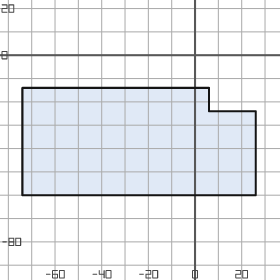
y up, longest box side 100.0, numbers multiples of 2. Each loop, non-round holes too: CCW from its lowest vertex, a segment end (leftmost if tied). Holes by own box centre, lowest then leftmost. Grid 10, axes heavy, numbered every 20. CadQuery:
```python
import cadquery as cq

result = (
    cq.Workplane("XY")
    .moveTo(-74.0, -60.0)
    .lineTo(26.0, -60.0)
    .lineTo(26.0, -24.0)
    .lineTo(6.0, -24.0)
    .lineTo(6.0, -14.0)
    .lineTo(-74.0, -14.0)
    .close()
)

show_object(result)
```